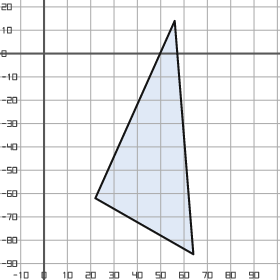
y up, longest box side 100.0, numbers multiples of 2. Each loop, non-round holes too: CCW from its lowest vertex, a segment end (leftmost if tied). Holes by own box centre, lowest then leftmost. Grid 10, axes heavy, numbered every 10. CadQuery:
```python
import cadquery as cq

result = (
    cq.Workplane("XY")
    .moveTo(64.0, -86.0)
    .lineTo(56.0, 14.0)
    .lineTo(22.0, -62.0)
    .close()
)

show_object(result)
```